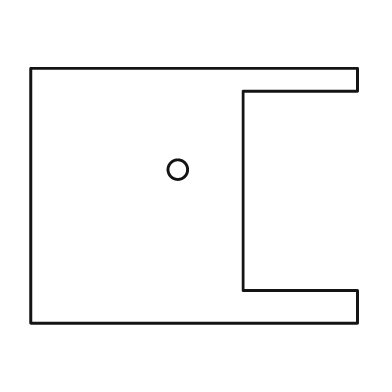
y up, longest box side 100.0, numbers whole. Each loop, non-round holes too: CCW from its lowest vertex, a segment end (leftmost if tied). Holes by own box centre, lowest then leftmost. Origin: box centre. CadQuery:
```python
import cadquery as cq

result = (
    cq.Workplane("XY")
    .moveTo(-50.0, -39.0)
    .lineTo(50.0, -39.0)
    .lineTo(50.0, -29.0)
    .lineTo(15.0, -29.0)
    .lineTo(15.0, 32.0)
    .lineTo(50.0, 32.0)
    .lineTo(50.0, 39.0)
    .lineTo(-50.0, 39.0)
    .close()
    .moveTo(-5.0, 8.0)
    .circle(3.0)
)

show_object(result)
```